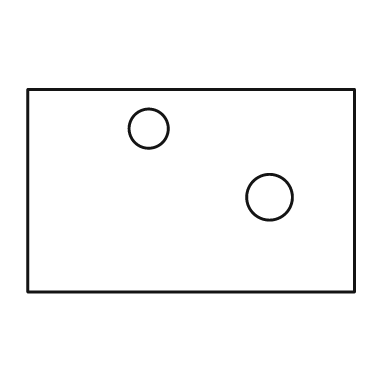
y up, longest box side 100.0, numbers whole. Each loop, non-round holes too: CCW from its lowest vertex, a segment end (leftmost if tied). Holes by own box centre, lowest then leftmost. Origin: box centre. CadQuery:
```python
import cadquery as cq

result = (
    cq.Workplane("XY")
    .moveTo(-50.0, -31.0)
    .lineTo(50.0, -31.0)
    .lineTo(50.0, 31.0)
    .lineTo(-50.0, 31.0)
    .close()
    .moveTo(24.0, -2.0)
    .circle(7.0)
    .moveTo(-13.0, 19.0)
    .circle(6.0)
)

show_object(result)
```